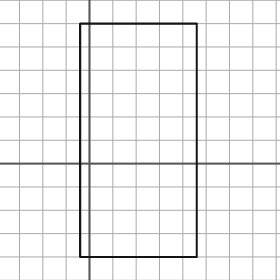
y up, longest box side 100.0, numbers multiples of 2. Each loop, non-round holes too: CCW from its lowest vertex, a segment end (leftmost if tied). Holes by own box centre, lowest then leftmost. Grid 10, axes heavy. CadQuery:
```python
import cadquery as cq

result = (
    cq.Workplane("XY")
    .moveTo(-4.0, -40.0)
    .lineTo(46.0, -40.0)
    .lineTo(46.0, 60.0)
    .lineTo(-4.0, 60.0)
    .close()
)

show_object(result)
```